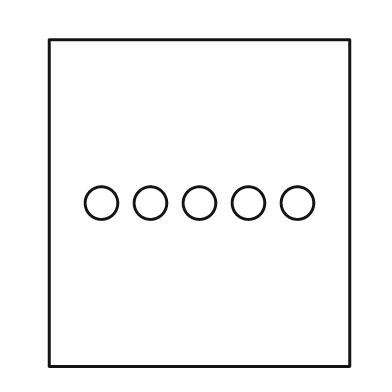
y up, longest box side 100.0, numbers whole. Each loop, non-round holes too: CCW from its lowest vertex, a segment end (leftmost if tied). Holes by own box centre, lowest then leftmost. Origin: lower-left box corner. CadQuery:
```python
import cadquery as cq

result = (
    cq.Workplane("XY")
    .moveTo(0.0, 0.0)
    .lineTo(92.0, 0.0)
    .lineTo(92.0, 100.0)
    .lineTo(0.0, 100.0)
    .close()
    .moveTo(16.0, 50.0)
    .circle(5.0)
    .moveTo(31.0, 50.0)
    .circle(5.0)
    .moveTo(46.0, 50.0)
    .circle(5.0)
    .moveTo(61.0, 50.0)
    .circle(5.0)
    .moveTo(76.0, 50.0)
    .circle(5.0)
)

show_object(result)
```